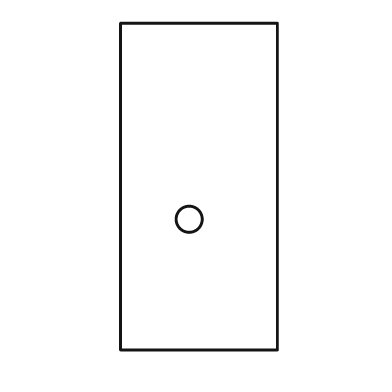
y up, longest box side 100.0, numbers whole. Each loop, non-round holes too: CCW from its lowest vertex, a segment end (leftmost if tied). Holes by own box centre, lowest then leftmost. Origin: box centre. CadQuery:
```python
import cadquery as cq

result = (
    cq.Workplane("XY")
    .moveTo(-24.0, -50.0)
    .lineTo(24.0, -50.0)
    .lineTo(24.0, 50.0)
    .lineTo(-24.0, 50.0)
    .close()
    .moveTo(-3.0, -10.0)
    .circle(4.0)
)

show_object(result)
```